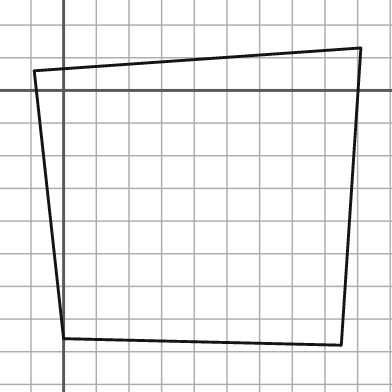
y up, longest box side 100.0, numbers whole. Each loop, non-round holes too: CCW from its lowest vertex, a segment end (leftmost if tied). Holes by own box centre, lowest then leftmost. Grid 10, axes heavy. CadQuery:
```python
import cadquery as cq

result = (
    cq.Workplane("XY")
    .moveTo(85.0, -78.0)
    .lineTo(91.0, 13.0)
    .lineTo(-9.0, 6.0)
    .lineTo(0.0, -76.0)
    .close()
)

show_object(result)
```